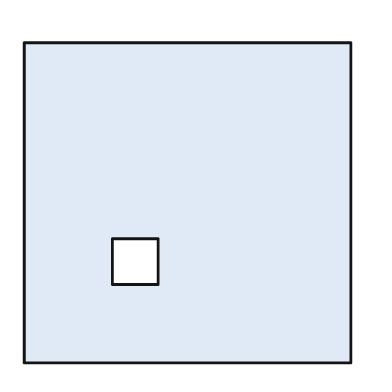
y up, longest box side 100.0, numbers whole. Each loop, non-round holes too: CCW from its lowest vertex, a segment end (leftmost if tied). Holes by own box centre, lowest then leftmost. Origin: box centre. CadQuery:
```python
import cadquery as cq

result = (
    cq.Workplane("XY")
    .moveTo(-50.0, -49.0)
    .lineTo(50.0, -49.0)
    .lineTo(50.0, 49.0)
    .lineTo(-50.0, 49.0)
    .close()
    .moveTo(-23.0, -25.0)
    .lineTo(-9.0, -25.0)
    .lineTo(-9.0, -11.0)
    .lineTo(-23.0, -11.0)
    .close()
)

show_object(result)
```